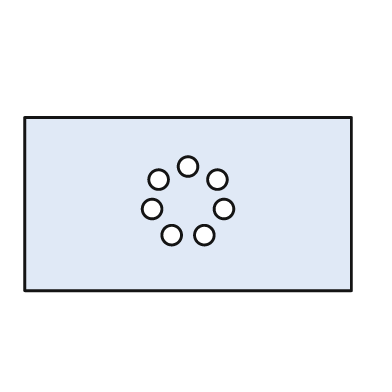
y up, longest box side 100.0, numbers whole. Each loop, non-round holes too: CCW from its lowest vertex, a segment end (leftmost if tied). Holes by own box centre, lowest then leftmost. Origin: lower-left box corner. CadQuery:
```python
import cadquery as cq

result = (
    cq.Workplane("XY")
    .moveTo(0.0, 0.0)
    .lineTo(100.0, 0.0)
    .lineTo(100.0, 53.0)
    .lineTo(0.0, 53.0)
    .close()
    .moveTo(45.0, 17.0)
    .circle(3.0)
    .moveTo(55.0, 17.0)
    .circle(3.0)
    .moveTo(39.0, 25.0)
    .circle(3.0)
    .moveTo(61.0, 25.0)
    .circle(3.0)
    .moveTo(41.0, 34.0)
    .circle(3.0)
    .moveTo(59.0, 34.0)
    .circle(3.0)
    .moveTo(50.0, 38.0)
    .circle(3.0)
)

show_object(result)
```